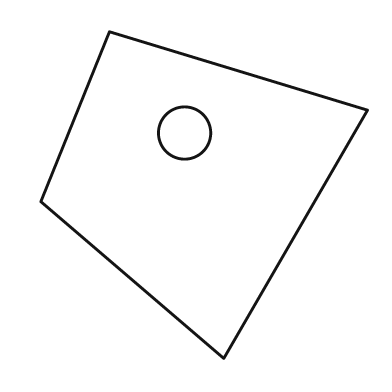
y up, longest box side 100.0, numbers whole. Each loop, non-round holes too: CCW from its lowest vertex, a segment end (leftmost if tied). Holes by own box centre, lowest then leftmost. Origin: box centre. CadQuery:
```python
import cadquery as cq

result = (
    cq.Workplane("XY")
    .moveTo(6.0, -50.0)
    .lineTo(50.0, 26.0)
    .lineTo(-29.0, 50.0)
    .lineTo(-50.0, -2.0)
    .close()
    .moveTo(-6.0, 19.0)
    .circle(8.0)
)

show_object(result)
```